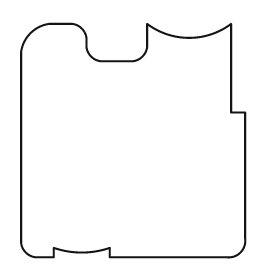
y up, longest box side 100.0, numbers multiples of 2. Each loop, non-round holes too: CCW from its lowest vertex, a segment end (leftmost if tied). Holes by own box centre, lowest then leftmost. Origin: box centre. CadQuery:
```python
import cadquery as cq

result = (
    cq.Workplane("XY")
    .moveTo(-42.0, -50.0)
    .lineTo(-34.0, -50.0)
    .lineTo(-34.0, -46.0)
    .threePointArc((-22.0, -48.0), (-10.0, -46.0))
    .lineTo(-10.0, -50.0)
    .lineTo(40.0, -50.0)
    .threePointArc((46.0, -48.0), (48.0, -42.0))
    .lineTo(48.0, 12.0)
    .lineTo(42.0, 12.0)
    .lineTo(42.0, 50.0)
    .threePointArc((24.0, 44.0), (6.0, 50.0))
    .lineTo(6.0, 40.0)
    .threePointArc((4.0, 36.0), (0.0, 34.0))
    .lineTo(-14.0, 34.0)
    .threePointArc((-18.0, 36.0), (-20.0, 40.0))
    .lineTo(-20.0, 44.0)
    .threePointArc((-22.0, 48.0), (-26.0, 50.0))
    .lineTo(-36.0, 50.0)
    .threePointArc((-44.0, 46.0), (-48.0, 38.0))
    .lineTo(-48.0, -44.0)
    .threePointArc((-46.0, -48.0), (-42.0, -50.0))
    .close()
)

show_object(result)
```